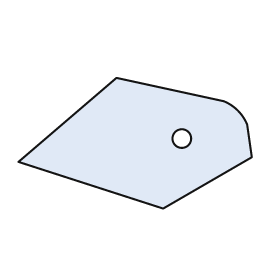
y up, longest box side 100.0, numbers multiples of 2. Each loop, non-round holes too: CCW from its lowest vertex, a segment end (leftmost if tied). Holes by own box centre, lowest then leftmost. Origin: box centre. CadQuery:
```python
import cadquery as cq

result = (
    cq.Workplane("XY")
    .moveTo(12.0, -28.0)
    .lineTo(50.0, -6.0)
    .lineTo(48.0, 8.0)
    .threePointArc((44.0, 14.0), (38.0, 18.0))
    .lineTo(-8.0, 28.0)
    .lineTo(-50.0, -8.0)
    .close()
    .moveTo(20.0, 2.0)
    .circle(4.0)
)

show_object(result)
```